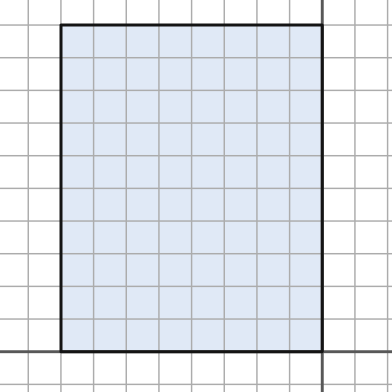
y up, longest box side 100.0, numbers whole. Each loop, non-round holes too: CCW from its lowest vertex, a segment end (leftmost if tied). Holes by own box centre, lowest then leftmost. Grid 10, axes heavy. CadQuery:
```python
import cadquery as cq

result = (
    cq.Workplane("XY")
    .moveTo(-80.0, 0.0)
    .lineTo(0.0, 0.0)
    .lineTo(0.0, 100.0)
    .lineTo(-80.0, 100.0)
    .close()
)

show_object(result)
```